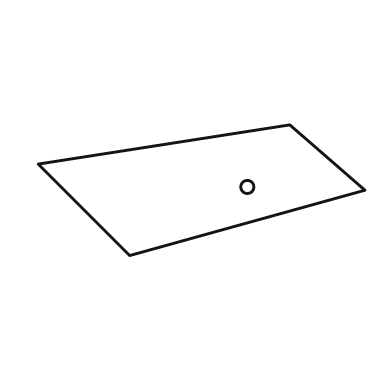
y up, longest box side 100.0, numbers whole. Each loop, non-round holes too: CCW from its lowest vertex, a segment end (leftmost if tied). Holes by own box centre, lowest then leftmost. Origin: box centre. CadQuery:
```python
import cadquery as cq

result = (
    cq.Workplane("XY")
    .moveTo(-22.0, -20.0)
    .lineTo(50.0, 0.0)
    .lineTo(27.0, 20.0)
    .lineTo(-50.0, 8.0)
    .close()
    .moveTo(14.0, 1.0)
    .circle(2.0)
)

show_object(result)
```